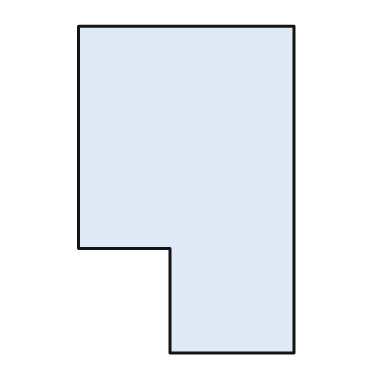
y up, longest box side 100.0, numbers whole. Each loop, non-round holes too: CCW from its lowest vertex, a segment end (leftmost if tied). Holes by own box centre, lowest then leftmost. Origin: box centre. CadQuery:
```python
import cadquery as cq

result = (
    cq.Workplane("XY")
    .moveTo(-5.0, -50.0)
    .lineTo(33.0, -50.0)
    .lineTo(33.0, 50.0)
    .lineTo(-33.0, 50.0)
    .lineTo(-33.0, -18.0)
    .lineTo(-5.0, -18.0)
    .close()
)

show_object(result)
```